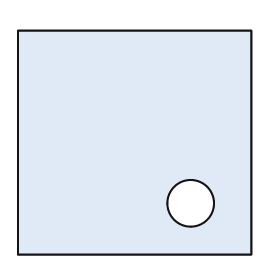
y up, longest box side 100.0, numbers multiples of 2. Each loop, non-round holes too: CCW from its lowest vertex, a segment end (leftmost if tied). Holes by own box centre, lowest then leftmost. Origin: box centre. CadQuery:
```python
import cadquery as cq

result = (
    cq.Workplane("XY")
    .moveTo(-50.0, -48.0)
    .lineTo(50.0, -48.0)
    .lineTo(50.0, 48.0)
    .lineTo(-50.0, 48.0)
    .close()
    .moveTo(24.0, -26.0)
    .circle(10.0)
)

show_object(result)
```